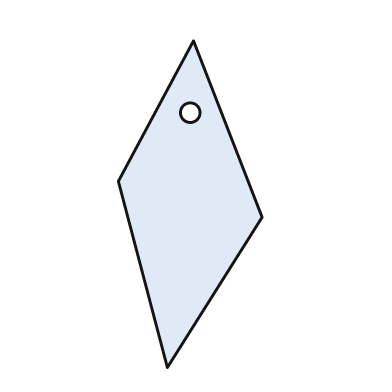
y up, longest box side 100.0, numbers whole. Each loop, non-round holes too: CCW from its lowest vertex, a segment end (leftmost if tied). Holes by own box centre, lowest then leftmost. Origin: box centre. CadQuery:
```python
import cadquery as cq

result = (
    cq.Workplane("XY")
    .moveTo(-7.0, -50.0)
    .lineTo(22.0, -4.0)
    .lineTo(1.0, 50.0)
    .lineTo(-22.0, 7.0)
    .close()
    .moveTo(0.0, 28.0)
    .circle(3.0)
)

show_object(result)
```